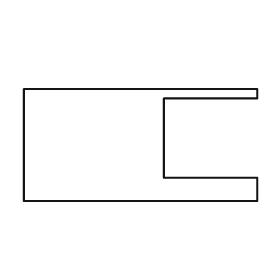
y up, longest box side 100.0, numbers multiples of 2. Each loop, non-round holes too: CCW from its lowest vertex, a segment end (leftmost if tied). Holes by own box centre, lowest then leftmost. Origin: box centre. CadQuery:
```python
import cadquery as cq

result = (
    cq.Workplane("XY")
    .moveTo(-50.0, -24.0)
    .lineTo(50.0, -24.0)
    .lineTo(50.0, -14.0)
    .lineTo(10.0, -14.0)
    .lineTo(10.0, 20.0)
    .lineTo(50.0, 20.0)
    .lineTo(50.0, 24.0)
    .lineTo(-50.0, 24.0)
    .close()
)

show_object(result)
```